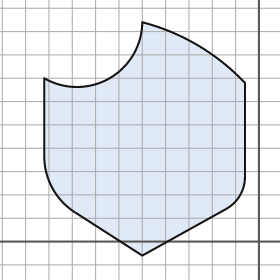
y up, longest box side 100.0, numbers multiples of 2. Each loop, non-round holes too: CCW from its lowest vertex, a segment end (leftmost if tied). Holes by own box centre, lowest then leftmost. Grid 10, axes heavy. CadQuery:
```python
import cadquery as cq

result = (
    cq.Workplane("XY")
    .moveTo(-50.0, -6.0)
    .lineTo(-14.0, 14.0)
    .threePointArc((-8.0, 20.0), (-6.0, 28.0))
    .lineTo(-6.0, 68.0)
    .threePointArc((-26.0, 84.0), (-50.0, 94.0))
    .threePointArc((-64.0, 70.0), (-92.0, 70.0))
    .lineTo(-92.0, 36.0)
    .threePointArc((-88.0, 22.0), (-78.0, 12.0))
    .close()
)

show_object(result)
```